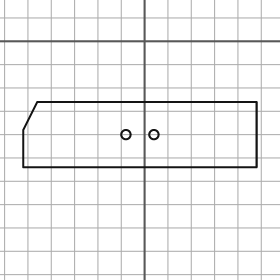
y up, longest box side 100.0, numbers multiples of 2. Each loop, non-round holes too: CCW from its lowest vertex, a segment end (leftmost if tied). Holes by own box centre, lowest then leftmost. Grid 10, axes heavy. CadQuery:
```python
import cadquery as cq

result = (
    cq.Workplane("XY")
    .moveTo(-52.0, -54.0)
    .lineTo(48.0, -54.0)
    .lineTo(48.0, -26.0)
    .lineTo(-46.0, -26.0)
    .lineTo(-52.0, -38.0)
    .close()
    .moveTo(-8.0, -40.0)
    .circle(2.0)
    .moveTo(4.0, -40.0)
    .circle(2.0)
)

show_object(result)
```